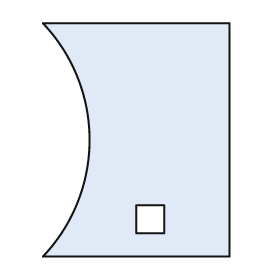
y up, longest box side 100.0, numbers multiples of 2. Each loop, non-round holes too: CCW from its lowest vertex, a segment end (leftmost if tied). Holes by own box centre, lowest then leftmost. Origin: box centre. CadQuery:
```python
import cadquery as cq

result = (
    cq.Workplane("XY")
    .moveTo(-40.0, -50.0)
    .lineTo(40.0, -50.0)
    .lineTo(40.0, 50.0)
    .lineTo(-40.0, 50.0)
    .threePointArc((-20.0, 0.0), (-40.0, -50.0))
    .close()
    .moveTo(0.0, -40.0)
    .lineTo(12.0, -40.0)
    .lineTo(12.0, -28.0)
    .lineTo(0.0, -28.0)
    .close()
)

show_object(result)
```